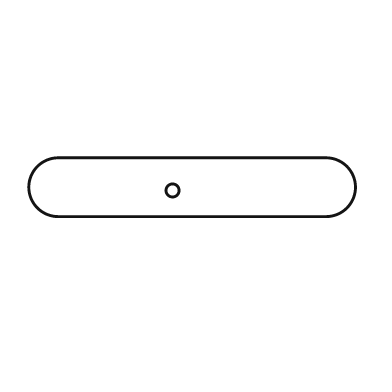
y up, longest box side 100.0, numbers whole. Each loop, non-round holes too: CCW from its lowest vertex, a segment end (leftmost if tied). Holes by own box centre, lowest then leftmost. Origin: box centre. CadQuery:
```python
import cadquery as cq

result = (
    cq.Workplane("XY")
    .moveTo(-41.0, -9.0)
    .lineTo(41.0, -9.0)
    .threePointArc((50.0, 0.0), (41.0, 9.0))
    .lineTo(-41.0, 9.0)
    .threePointArc((-50.0, 0.0), (-41.0, -9.0))
    .close()
    .moveTo(-6.0, -1.0)
    .circle(2.0)
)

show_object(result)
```